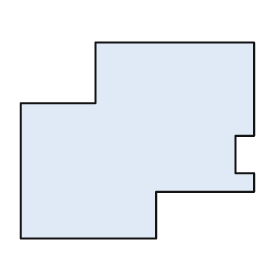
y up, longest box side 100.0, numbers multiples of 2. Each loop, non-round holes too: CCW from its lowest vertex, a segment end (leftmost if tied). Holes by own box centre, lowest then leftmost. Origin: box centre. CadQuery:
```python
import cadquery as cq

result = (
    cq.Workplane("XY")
    .moveTo(-50.0, -42.0)
    .lineTo(8.0, -42.0)
    .lineTo(8.0, -22.0)
    .lineTo(50.0, -22.0)
    .lineTo(50.0, -14.0)
    .lineTo(42.0, -14.0)
    .lineTo(42.0, 2.0)
    .lineTo(50.0, 2.0)
    .lineTo(50.0, 42.0)
    .lineTo(-18.0, 42.0)
    .lineTo(-18.0, 16.0)
    .lineTo(-50.0, 16.0)
    .close()
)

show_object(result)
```